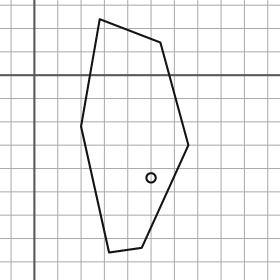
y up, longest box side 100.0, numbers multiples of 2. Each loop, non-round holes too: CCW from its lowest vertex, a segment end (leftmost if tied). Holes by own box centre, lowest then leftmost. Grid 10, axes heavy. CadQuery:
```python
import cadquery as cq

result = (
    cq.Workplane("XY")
    .moveTo(32.0, -76.0)
    .lineTo(46.0, -74.0)
    .lineTo(66.0, -30.0)
    .lineTo(54.0, 14.0)
    .lineTo(28.0, 24.0)
    .lineTo(20.0, -22.0)
    .close()
    .moveTo(50.0, -44.0)
    .circle(2.0)
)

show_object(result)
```